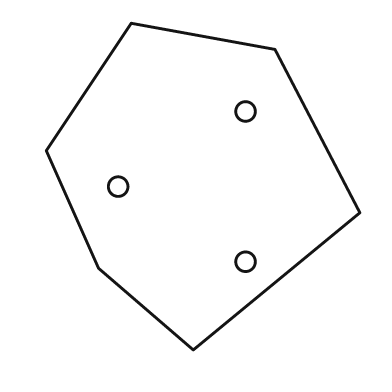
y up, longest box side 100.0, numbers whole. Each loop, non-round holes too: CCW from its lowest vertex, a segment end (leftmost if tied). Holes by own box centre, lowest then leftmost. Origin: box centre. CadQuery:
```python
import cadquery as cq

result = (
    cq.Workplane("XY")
    .moveTo(-3.0, -50.0)
    .lineTo(48.0, -8.0)
    .lineTo(22.0, 42.0)
    .lineTo(-22.0, 50.0)
    .lineTo(-48.0, 11.0)
    .lineTo(-32.0, -25.0)
    .close()
    .moveTo(13.0, -23.0)
    .circle(3.0)
    .moveTo(-26.0, 0.0)
    .circle(3.0)
    .moveTo(13.0, 23.0)
    .circle(3.0)
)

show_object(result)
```